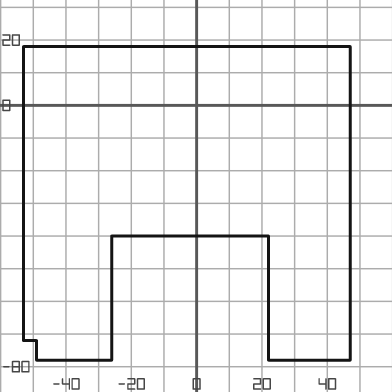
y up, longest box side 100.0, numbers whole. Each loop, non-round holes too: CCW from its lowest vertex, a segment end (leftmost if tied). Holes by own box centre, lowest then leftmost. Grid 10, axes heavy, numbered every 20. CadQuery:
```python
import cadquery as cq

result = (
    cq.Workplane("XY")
    .moveTo(-49.0, -78.0)
    .lineTo(-26.0, -78.0)
    .lineTo(-26.0, -40.0)
    .lineTo(22.0, -40.0)
    .lineTo(22.0, -78.0)
    .lineTo(47.0, -78.0)
    .lineTo(47.0, 18.0)
    .lineTo(-53.0, 18.0)
    .lineTo(-53.0, -72.0)
    .lineTo(-49.0, -72.0)
    .close()
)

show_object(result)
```